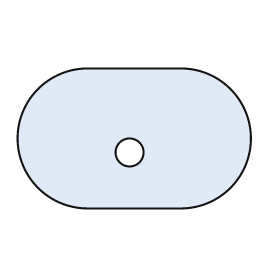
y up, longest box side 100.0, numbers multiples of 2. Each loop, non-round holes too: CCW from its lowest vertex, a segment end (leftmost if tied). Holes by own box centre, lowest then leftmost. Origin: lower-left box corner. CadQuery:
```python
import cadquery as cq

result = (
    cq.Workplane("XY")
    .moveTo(30.0, 0.0)
    .lineTo(70.0, 0.0)
    .threePointArc((100.0, 30.0), (70.0, 60.0))
    .lineTo(30.0, 60.0)
    .threePointArc((0.0, 30.0), (30.0, 0.0))
    .close()
    .moveTo(48.0, 24.0)
    .circle(6.0)
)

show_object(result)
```